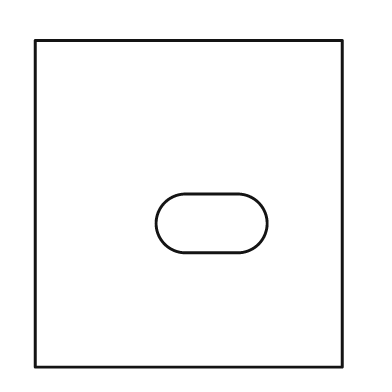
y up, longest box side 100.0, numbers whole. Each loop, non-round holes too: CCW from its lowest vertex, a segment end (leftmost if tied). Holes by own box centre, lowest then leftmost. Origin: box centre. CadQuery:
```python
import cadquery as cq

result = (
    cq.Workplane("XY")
    .moveTo(-47.0, -50.0)
    .lineTo(47.0, -50.0)
    .lineTo(47.0, 50.0)
    .lineTo(-47.0, 50.0)
    .close()
    .moveTo(-1.0, -15.0)
    .lineTo(15.0, -15.0)
    .threePointArc((24.0, -6.0), (15.0, 3.0))
    .lineTo(-1.0, 3.0)
    .threePointArc((-10.0, -6.0), (-1.0, -15.0))
    .close()
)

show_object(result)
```